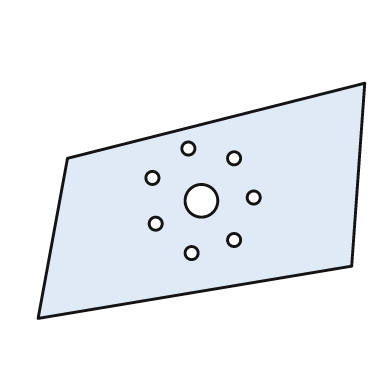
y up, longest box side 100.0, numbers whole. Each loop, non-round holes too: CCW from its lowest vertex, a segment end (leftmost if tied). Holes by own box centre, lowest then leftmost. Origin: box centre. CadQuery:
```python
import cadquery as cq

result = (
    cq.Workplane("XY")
    .moveTo(-50.0, -36.0)
    .lineTo(46.0, -20.0)
    .lineTo(50.0, 36.0)
    .lineTo(-41.0, 13.0)
    .close()
    .moveTo(-3.0, -16.0)
    .circle(2.0)
    .moveTo(10.0, -12.0)
    .circle(2.0)
    .moveTo(-14.0, -7.0)
    .circle(2.0)
    .moveTo(0.0, 0.0)
    .circle(5.0)
    .moveTo(16.0, 1.0)
    .circle(2.0)
    .moveTo(-15.0, 7.0)
    .circle(2.0)
    .moveTo(10.0, 13.0)
    .circle(2.0)
    .moveTo(-4.0, 16.0)
    .circle(2.0)
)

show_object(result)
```